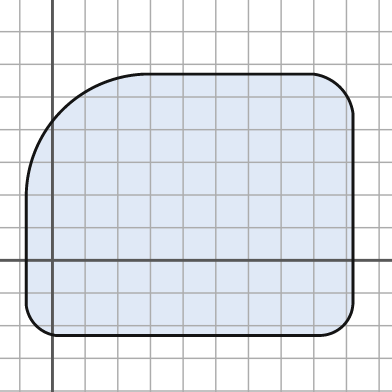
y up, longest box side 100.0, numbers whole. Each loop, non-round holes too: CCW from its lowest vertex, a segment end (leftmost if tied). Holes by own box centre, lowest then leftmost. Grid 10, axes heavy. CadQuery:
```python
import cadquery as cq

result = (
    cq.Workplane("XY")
    .moveTo(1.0, -23.0)
    .lineTo(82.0, -23.0)
    .threePointArc((89.0, -20.0), (92.0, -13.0))
    .lineTo(92.0, 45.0)
    .threePointArc((88.0, 53.0), (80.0, 57.0))
    .lineTo(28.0, 57.0)
    .threePointArc((3.0, 46.0), (-8.0, 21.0))
    .lineTo(-8.0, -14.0)
    .threePointArc((-5.0, -20.0), (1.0, -23.0))
    .close()
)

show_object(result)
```